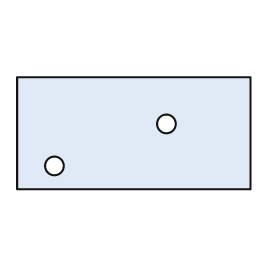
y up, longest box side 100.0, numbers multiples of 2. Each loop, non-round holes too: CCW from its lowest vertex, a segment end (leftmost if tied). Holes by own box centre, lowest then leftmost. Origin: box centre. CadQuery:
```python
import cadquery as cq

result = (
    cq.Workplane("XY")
    .moveTo(-50.0, -24.0)
    .lineTo(50.0, -24.0)
    .lineTo(50.0, 24.0)
    .lineTo(-50.0, 24.0)
    .close()
    .moveTo(-34.0, -14.0)
    .circle(4.0)
    .moveTo(14.0, 4.0)
    .circle(4.0)
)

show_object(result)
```